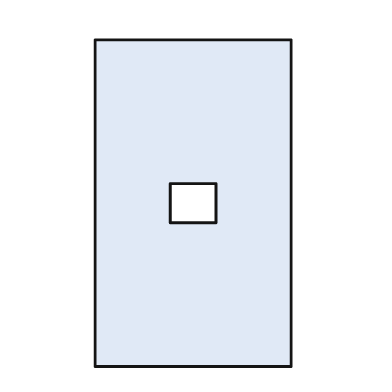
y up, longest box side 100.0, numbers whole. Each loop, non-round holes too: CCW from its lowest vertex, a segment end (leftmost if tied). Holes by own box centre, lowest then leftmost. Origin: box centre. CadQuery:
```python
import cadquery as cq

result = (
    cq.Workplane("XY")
    .moveTo(-30.0, -50.0)
    .lineTo(30.0, -50.0)
    .lineTo(30.0, 50.0)
    .lineTo(-30.0, 50.0)
    .close()
    .moveTo(-7.0, -6.0)
    .lineTo(7.0, -6.0)
    .lineTo(7.0, 6.0)
    .lineTo(-7.0, 6.0)
    .close()
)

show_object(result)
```